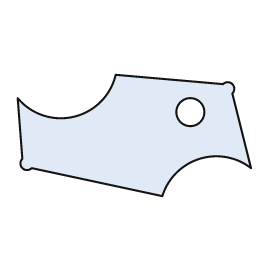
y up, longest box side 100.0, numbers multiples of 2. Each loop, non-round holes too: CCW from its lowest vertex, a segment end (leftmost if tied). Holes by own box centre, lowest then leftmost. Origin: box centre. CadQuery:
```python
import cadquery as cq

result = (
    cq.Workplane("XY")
    .moveTo(12.0, -26.0)
    .threePointArc((28.0, -10.0), (50.0, -14.0))
    .lineTo(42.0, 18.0)
    .threePointArc((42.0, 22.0), (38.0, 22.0))
    .lineTo(-8.0, 26.0)
    .threePointArc((-26.0, 8.0), (-50.0, 16.0))
    .lineTo(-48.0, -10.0)
    .threePointArc((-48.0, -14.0), (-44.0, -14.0))
    .close()
    .moveTo(24.0, 10.0)
    .circle(6.0)
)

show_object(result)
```